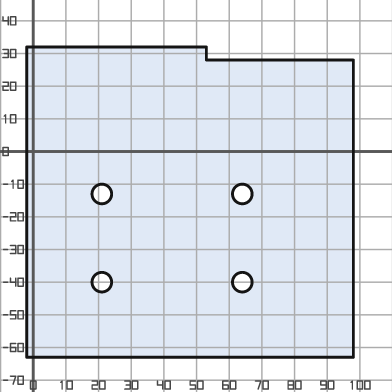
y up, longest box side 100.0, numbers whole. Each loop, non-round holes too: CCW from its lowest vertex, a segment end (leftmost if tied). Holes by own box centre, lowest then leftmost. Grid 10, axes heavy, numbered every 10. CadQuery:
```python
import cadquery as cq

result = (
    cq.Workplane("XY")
    .moveTo(-2.0, -63.0)
    .lineTo(98.0, -63.0)
    .lineTo(98.0, 28.0)
    .lineTo(53.0, 28.0)
    .lineTo(53.0, 32.0)
    .lineTo(-2.0, 32.0)
    .close()
    .moveTo(21.0, -40.0)
    .circle(3.0)
    .moveTo(64.0, -40.0)
    .circle(3.0)
    .moveTo(21.0, -13.0)
    .circle(3.0)
    .moveTo(64.0, -13.0)
    .circle(3.0)
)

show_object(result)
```